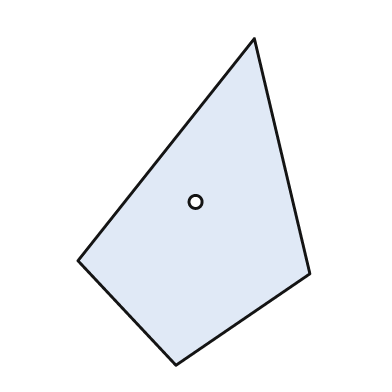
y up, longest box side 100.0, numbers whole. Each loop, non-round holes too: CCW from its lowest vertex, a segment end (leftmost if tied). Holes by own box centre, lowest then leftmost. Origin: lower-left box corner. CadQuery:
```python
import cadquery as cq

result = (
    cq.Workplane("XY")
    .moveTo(30.0, 0.0)
    .lineTo(71.0, 28.0)
    .lineTo(54.0, 100.0)
    .lineTo(0.0, 32.0)
    .close()
    .moveTo(36.0, 50.0)
    .circle(2.0)
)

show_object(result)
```